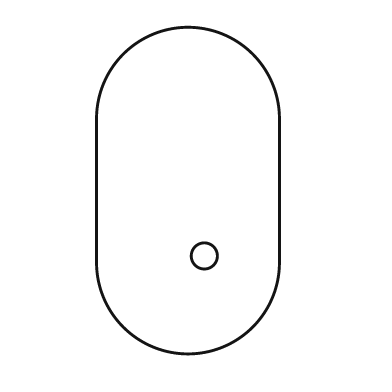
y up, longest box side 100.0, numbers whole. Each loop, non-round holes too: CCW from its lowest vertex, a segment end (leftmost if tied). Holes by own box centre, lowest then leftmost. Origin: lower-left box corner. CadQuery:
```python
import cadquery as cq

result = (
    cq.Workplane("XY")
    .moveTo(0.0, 28.0)
    .threePointArc((28.0, 0.0), (56.0, 28.0))
    .lineTo(56.0, 72.0)
    .threePointArc((28.0, 100.0), (0.0, 72.0))
    .close()
    .moveTo(33.0, 30.0)
    .circle(4.0)
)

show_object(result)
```